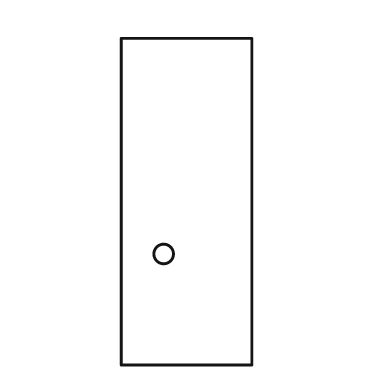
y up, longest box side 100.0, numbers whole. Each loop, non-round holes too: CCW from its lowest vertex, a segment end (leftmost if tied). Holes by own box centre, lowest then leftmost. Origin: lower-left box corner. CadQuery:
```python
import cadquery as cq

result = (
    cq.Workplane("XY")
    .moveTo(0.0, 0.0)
    .lineTo(40.0, 0.0)
    .lineTo(40.0, 100.0)
    .lineTo(0.0, 100.0)
    .close()
    .moveTo(13.0, 34.0)
    .circle(3.0)
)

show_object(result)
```